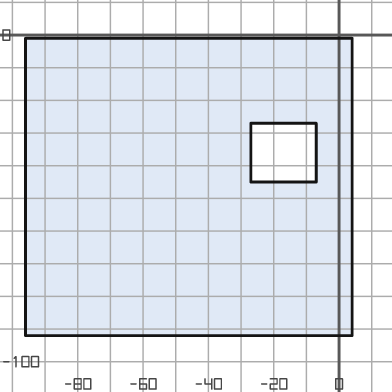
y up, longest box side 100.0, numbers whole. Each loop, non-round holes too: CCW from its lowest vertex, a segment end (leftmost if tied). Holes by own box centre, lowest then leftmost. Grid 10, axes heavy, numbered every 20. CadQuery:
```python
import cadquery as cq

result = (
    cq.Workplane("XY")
    .moveTo(-96.0, -92.0)
    .lineTo(4.0, -92.0)
    .lineTo(4.0, -1.0)
    .lineTo(-96.0, -1.0)
    .close()
    .moveTo(-27.0, -45.0)
    .lineTo(-7.0, -45.0)
    .lineTo(-7.0, -27.0)
    .lineTo(-27.0, -27.0)
    .close()
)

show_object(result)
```